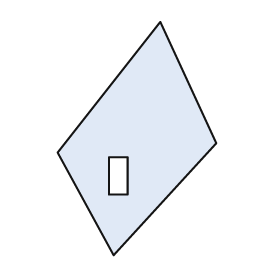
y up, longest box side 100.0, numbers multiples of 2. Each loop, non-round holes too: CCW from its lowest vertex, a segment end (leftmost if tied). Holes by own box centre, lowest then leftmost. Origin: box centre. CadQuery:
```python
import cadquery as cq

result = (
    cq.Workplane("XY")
    .moveTo(-10.0, -50.0)
    .lineTo(34.0, -2.0)
    .lineTo(10.0, 50.0)
    .lineTo(-34.0, -6.0)
    .close()
    .moveTo(-12.0, -24.0)
    .lineTo(-4.0, -24.0)
    .lineTo(-4.0, -8.0)
    .lineTo(-12.0, -8.0)
    .close()
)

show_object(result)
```